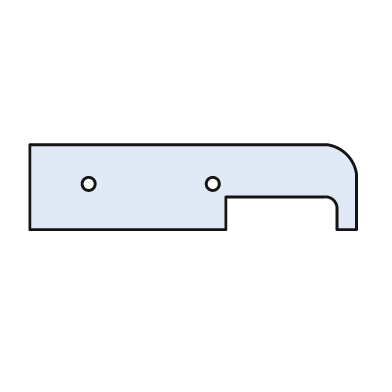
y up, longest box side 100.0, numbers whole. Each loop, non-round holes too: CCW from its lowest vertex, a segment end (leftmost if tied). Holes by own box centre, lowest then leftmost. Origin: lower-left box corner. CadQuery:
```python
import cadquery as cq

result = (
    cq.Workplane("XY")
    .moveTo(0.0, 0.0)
    .lineTo(60.0, 0.0)
    .lineTo(60.0, 10.0)
    .lineTo(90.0, 10.0)
    .threePointArc((93.0, 9.0), (94.0, 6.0))
    .lineTo(94.0, 0.0)
    .lineTo(100.0, 0.0)
    .lineTo(100.0, 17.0)
    .threePointArc((97.0, 23.0), (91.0, 26.0))
    .lineTo(0.0, 26.0)
    .close()
    .moveTo(18.0, 14.0)
    .circle(2.0)
    .moveTo(56.0, 14.0)
    .circle(2.0)
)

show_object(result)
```